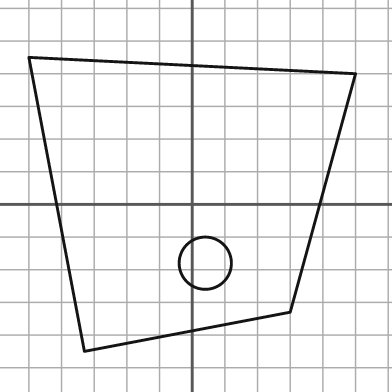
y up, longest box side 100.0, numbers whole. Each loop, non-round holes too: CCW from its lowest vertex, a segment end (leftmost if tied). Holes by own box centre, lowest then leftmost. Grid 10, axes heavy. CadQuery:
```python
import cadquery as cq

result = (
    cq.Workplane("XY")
    .moveTo(-33.0, -45.0)
    .lineTo(30.0, -33.0)
    .lineTo(50.0, 40.0)
    .lineTo(-50.0, 45.0)
    .close()
    .moveTo(4.0, -18.0)
    .circle(8.0)
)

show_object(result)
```